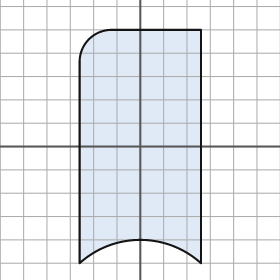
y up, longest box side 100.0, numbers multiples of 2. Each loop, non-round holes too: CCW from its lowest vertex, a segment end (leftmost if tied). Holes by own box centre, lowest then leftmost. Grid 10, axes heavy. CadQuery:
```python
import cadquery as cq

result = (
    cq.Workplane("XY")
    .moveTo(-26.0, -50.0)
    .threePointArc((0.0, -40.0), (26.0, -50.0))
    .lineTo(26.0, 50.0)
    .lineTo(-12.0, 50.0)
    .threePointArc((-22.0, 46.0), (-26.0, 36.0))
    .close()
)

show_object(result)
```